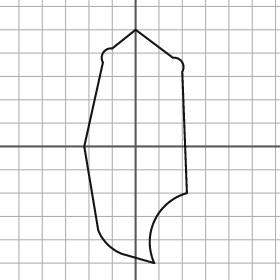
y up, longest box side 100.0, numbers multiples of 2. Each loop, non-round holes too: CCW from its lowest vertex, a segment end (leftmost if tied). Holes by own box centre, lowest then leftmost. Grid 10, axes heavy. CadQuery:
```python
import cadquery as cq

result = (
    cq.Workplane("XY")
    .moveTo(8.0, -50.0)
    .threePointArc((8.0, -32.0), (22.0, -20.0))
    .lineTo(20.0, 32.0)
    .threePointArc((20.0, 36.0), (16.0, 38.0))
    .lineTo(0.0, 50.0)
    .lineTo(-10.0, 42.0)
    .threePointArc((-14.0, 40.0), (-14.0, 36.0))
    .lineTo(-22.0, 0.0)
    .lineTo(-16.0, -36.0)
    .threePointArc((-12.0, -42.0), (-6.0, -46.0))
    .close()
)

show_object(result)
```